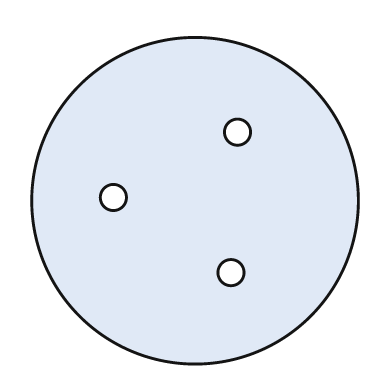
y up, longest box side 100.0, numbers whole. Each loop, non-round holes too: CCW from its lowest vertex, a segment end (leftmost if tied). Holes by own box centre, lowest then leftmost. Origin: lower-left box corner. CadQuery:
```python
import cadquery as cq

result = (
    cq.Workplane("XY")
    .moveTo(50.0, 50.0)
    .circle(50.0)
    .moveTo(61.0, 28.0)
    .circle(4.0)
    .moveTo(25.0, 51.0)
    .circle(4.0)
    .moveTo(63.0, 71.0)
    .circle(4.0)
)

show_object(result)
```